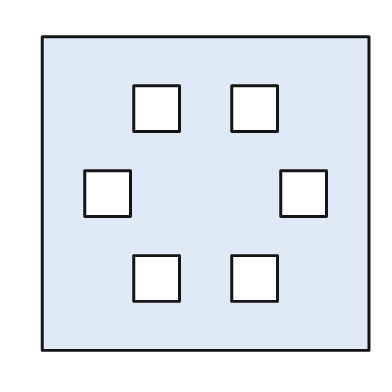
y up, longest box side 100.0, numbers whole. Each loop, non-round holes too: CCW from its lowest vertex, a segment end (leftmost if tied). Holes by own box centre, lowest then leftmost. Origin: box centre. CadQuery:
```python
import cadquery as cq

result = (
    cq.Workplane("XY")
    .moveTo(-50.0, -48.0)
    .lineTo(50.0, -48.0)
    .lineTo(50.0, 48.0)
    .lineTo(-50.0, 48.0)
    .close()
    .moveTo(-22.0, -33.0)
    .lineTo(-8.0, -33.0)
    .lineTo(-8.0, -19.0)
    .lineTo(-22.0, -19.0)
    .close()
    .moveTo(8.0, -33.0)
    .lineTo(22.0, -33.0)
    .lineTo(22.0, -19.0)
    .lineTo(8.0, -19.0)
    .close()
    .moveTo(-37.0, -7.0)
    .lineTo(-23.0, -7.0)
    .lineTo(-23.0, 7.0)
    .lineTo(-37.0, 7.0)
    .close()
    .moveTo(23.0, -7.0)
    .lineTo(37.0, -7.0)
    .lineTo(37.0, 7.0)
    .lineTo(23.0, 7.0)
    .close()
    .moveTo(-22.0, 19.0)
    .lineTo(-8.0, 19.0)
    .lineTo(-8.0, 33.0)
    .lineTo(-22.0, 33.0)
    .close()
    .moveTo(8.0, 19.0)
    .lineTo(22.0, 19.0)
    .lineTo(22.0, 33.0)
    .lineTo(8.0, 33.0)
    .close()
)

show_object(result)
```